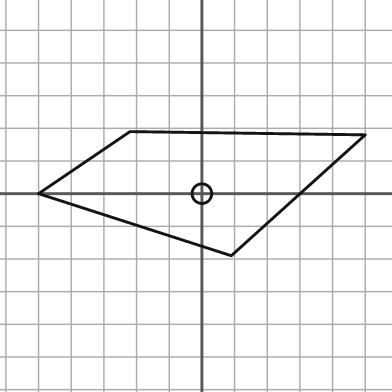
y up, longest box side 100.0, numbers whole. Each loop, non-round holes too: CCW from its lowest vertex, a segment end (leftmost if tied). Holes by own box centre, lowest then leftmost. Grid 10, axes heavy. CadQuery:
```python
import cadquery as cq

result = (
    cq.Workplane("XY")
    .moveTo(9.0, -19.0)
    .lineTo(50.0, 18.0)
    .lineTo(-22.0, 19.0)
    .lineTo(-50.0, 0.0)
    .close()
    .moveTo(0.0, 0.0)
    .circle(3.0)
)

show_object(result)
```